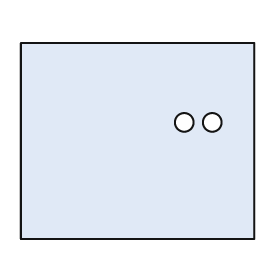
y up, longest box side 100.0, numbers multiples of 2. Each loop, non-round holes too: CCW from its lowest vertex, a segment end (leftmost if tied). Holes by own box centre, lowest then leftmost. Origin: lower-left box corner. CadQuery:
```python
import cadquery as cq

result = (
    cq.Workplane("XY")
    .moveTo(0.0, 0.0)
    .lineTo(100.0, 0.0)
    .lineTo(100.0, 84.0)
    .lineTo(0.0, 84.0)
    .close()
    .moveTo(70.0, 50.0)
    .circle(4.0)
    .moveTo(82.0, 50.0)
    .circle(4.0)
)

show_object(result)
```